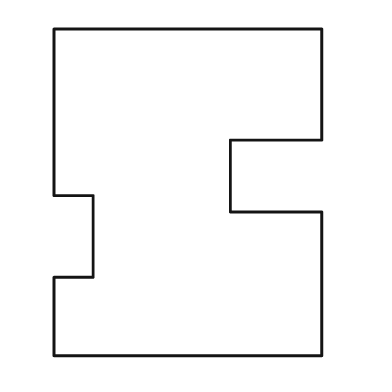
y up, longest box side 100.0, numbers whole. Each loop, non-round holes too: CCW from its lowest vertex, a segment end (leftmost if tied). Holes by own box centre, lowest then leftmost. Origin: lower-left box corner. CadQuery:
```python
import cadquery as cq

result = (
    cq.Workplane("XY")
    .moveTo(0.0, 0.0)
    .lineTo(82.0, 0.0)
    .lineTo(82.0, 44.0)
    .lineTo(54.0, 44.0)
    .lineTo(54.0, 66.0)
    .lineTo(82.0, 66.0)
    .lineTo(82.0, 100.0)
    .lineTo(0.0, 100.0)
    .lineTo(0.0, 49.0)
    .lineTo(12.0, 49.0)
    .lineTo(12.0, 24.0)
    .lineTo(0.0, 24.0)
    .close()
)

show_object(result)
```